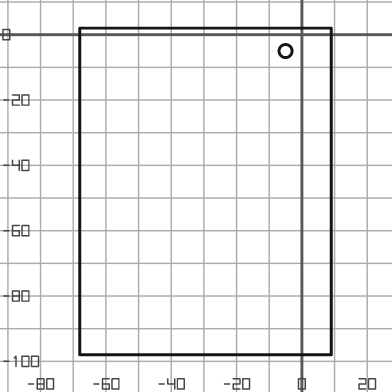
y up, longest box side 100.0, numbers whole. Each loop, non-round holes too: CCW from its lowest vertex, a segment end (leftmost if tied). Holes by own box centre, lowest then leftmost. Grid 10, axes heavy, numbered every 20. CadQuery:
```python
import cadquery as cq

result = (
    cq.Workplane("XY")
    .moveTo(-68.0, -98.0)
    .lineTo(9.0, -98.0)
    .lineTo(9.0, 2.0)
    .lineTo(-68.0, 2.0)
    .close()
    .moveTo(-5.0, -5.0)
    .circle(2.0)
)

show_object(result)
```